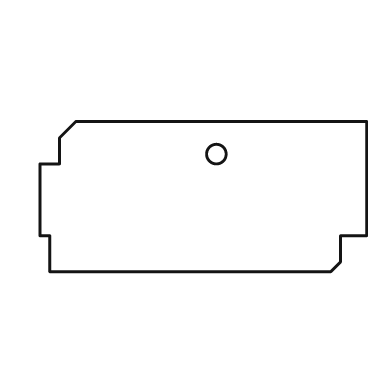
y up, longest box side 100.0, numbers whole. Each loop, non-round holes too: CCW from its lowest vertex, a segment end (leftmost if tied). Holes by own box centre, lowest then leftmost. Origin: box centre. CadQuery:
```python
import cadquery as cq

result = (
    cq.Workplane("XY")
    .moveTo(-47.0, -23.0)
    .lineTo(39.0, -23.0)
    .lineTo(42.0, -20.0)
    .lineTo(42.0, -12.0)
    .lineTo(50.0, -12.0)
    .lineTo(50.0, 23.0)
    .lineTo(-39.0, 23.0)
    .lineTo(-44.0, 18.0)
    .lineTo(-44.0, 10.0)
    .lineTo(-50.0, 10.0)
    .lineTo(-50.0, -12.0)
    .lineTo(-47.0, -12.0)
    .close()
    .moveTo(4.0, 13.0)
    .circle(3.0)
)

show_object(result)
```